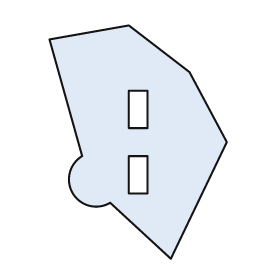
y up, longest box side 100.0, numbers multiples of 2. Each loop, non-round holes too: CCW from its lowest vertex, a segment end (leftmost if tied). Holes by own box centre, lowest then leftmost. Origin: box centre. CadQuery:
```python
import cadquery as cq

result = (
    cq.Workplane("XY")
    .moveTo(14.0, -50.0)
    .lineTo(38.0, 0.0)
    .lineTo(22.0, 30.0)
    .lineTo(-4.0, 50.0)
    .lineTo(-38.0, 44.0)
    .lineTo(-24.0, -6.0)
    .threePointArc((-28.0, -22.0), (-12.0, -26.0))
    .close()
    .moveTo(-4.0, -22.0)
    .lineTo(4.0, -22.0)
    .lineTo(4.0, -6.0)
    .lineTo(-4.0, -6.0)
    .close()
    .moveTo(-4.0, 6.0)
    .lineTo(4.0, 6.0)
    .lineTo(4.0, 22.0)
    .lineTo(-4.0, 22.0)
    .close()
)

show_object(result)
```